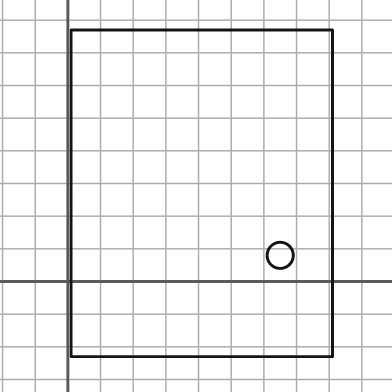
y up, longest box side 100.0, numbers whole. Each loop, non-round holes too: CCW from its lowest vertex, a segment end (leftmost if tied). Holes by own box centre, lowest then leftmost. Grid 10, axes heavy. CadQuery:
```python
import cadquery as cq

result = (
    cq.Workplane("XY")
    .moveTo(1.0, -23.0)
    .lineTo(81.0, -23.0)
    .lineTo(81.0, 77.0)
    .lineTo(1.0, 77.0)
    .close()
    .moveTo(65.0, 8.0)
    .circle(4.0)
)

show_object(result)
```